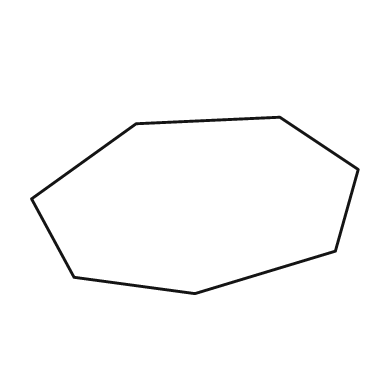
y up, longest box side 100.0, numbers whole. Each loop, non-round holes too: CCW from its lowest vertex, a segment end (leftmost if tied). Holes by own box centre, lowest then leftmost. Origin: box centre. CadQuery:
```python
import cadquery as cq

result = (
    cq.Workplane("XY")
    .moveTo(0.0, -27.0)
    .lineTo(43.0, -14.0)
    .lineTo(50.0, 11.0)
    .lineTo(26.0, 27.0)
    .lineTo(-18.0, 25.0)
    .lineTo(-50.0, 2.0)
    .lineTo(-37.0, -22.0)
    .close()
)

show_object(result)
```